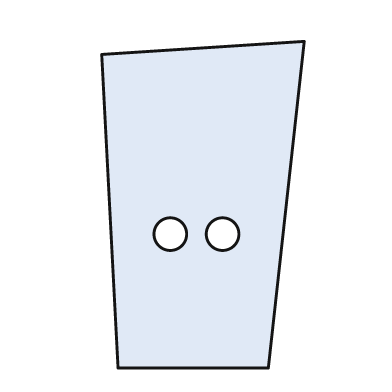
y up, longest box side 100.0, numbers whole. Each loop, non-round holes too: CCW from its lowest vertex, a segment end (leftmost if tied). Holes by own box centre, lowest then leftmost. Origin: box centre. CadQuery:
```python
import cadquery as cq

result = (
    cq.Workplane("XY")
    .moveTo(-26.0, -50.0)
    .lineTo(20.0, -50.0)
    .lineTo(31.0, 50.0)
    .lineTo(-31.0, 46.0)
    .close()
    .moveTo(-10.0, -9.0)
    .circle(5.0)
    .moveTo(6.0, -9.0)
    .circle(5.0)
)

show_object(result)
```